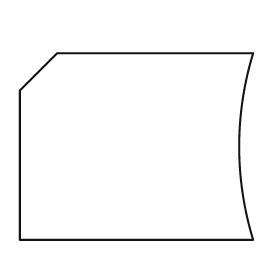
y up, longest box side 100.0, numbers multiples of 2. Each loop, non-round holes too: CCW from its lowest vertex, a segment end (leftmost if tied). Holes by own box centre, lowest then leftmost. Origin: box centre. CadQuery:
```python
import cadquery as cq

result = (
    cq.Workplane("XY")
    .moveTo(-50.0, -40.0)
    .lineTo(50.0, -40.0)
    .threePointArc((44.0, 0.0), (50.0, 40.0))
    .lineTo(-34.0, 40.0)
    .lineTo(-50.0, 24.0)
    .close()
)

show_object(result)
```